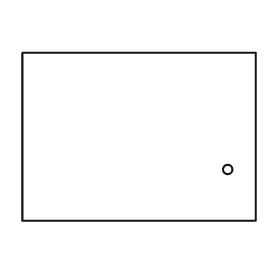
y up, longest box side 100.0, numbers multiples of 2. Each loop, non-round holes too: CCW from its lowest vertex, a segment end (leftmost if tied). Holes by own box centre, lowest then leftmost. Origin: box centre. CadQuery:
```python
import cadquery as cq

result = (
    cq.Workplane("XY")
    .moveTo(-50.0, -36.0)
    .lineTo(50.0, -36.0)
    .lineTo(50.0, 36.0)
    .lineTo(-50.0, 36.0)
    .close()
    .moveTo(38.0, -14.0)
    .circle(2.0)
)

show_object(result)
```